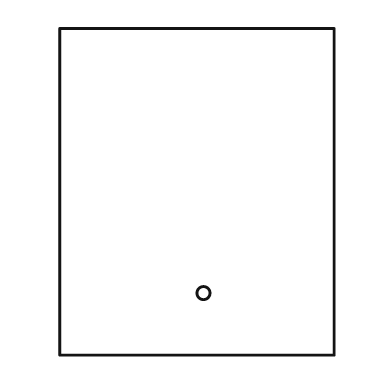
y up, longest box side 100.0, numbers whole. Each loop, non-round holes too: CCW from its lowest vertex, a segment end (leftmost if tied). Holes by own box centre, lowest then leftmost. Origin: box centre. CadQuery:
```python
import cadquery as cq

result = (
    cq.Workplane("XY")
    .moveTo(-42.0, -50.0)
    .lineTo(42.0, -50.0)
    .lineTo(42.0, 50.0)
    .lineTo(-42.0, 50.0)
    .close()
    .moveTo(2.0, -31.0)
    .circle(2.0)
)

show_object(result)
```